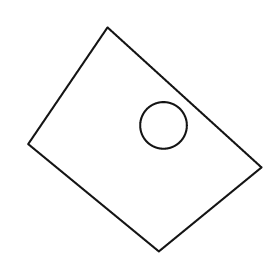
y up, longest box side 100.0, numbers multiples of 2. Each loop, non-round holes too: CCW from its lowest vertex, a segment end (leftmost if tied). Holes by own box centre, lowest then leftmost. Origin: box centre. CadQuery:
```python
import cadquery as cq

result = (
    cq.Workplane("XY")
    .moveTo(6.0, -48.0)
    .lineTo(50.0, -12.0)
    .lineTo(-16.0, 48.0)
    .lineTo(-50.0, -2.0)
    .close()
    .moveTo(8.0, 6.0)
    .circle(10.0)
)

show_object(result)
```